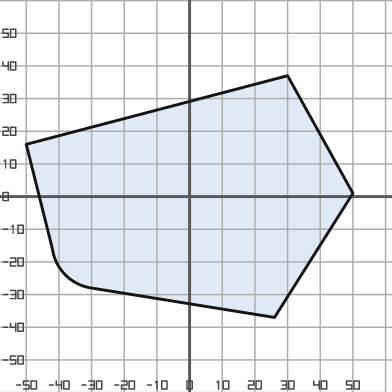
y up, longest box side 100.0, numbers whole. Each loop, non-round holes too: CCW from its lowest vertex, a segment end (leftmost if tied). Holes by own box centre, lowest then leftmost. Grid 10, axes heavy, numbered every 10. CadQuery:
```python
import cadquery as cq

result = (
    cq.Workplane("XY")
    .moveTo(26.0, -37.0)
    .lineTo(50.0, 1.0)
    .lineTo(30.0, 37.0)
    .lineTo(-50.0, 16.0)
    .lineTo(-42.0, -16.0)
    .threePointArc((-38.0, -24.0), (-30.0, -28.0))
    .close()
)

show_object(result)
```